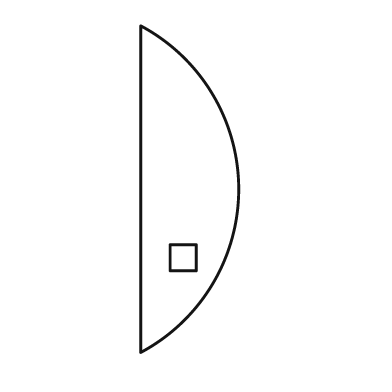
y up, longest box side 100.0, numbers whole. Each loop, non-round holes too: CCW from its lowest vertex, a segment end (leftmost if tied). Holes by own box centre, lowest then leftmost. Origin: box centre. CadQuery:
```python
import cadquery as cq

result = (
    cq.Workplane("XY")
    .moveTo(-15.0, -50.0)
    .threePointArc((15.0, 0.0), (-15.0, 50.0))
    .close()
    .moveTo(-6.0, -25.0)
    .lineTo(2.0, -25.0)
    .lineTo(2.0, -17.0)
    .lineTo(-6.0, -17.0)
    .close()
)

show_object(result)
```